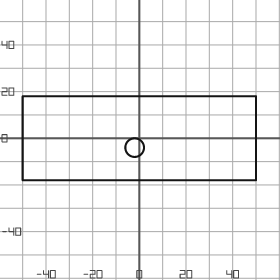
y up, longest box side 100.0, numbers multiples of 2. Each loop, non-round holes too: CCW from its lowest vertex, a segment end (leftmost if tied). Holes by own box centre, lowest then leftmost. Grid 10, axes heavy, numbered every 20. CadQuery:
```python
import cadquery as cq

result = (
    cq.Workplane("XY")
    .moveTo(-50.0, -18.0)
    .lineTo(50.0, -18.0)
    .lineTo(50.0, 18.0)
    .lineTo(-50.0, 18.0)
    .close()
    .moveTo(-2.0, -4.0)
    .circle(4.0)
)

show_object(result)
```